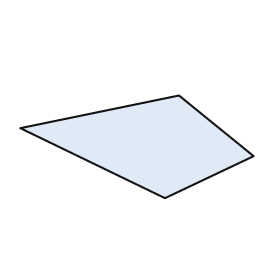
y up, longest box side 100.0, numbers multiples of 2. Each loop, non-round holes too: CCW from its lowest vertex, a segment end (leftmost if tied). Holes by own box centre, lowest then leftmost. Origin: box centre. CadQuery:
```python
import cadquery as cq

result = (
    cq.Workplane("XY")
    .moveTo(12.0, -22.0)
    .lineTo(50.0, -4.0)
    .lineTo(18.0, 22.0)
    .lineTo(-50.0, 8.0)
    .close()
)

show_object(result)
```